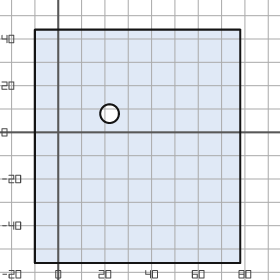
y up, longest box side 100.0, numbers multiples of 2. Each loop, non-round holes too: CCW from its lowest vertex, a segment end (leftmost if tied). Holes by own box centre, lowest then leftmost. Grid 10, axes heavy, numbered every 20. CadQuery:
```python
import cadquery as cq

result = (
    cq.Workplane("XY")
    .moveTo(-10.0, -56.0)
    .lineTo(78.0, -56.0)
    .lineTo(78.0, 44.0)
    .lineTo(-10.0, 44.0)
    .close()
    .moveTo(22.0, 8.0)
    .circle(4.0)
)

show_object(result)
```